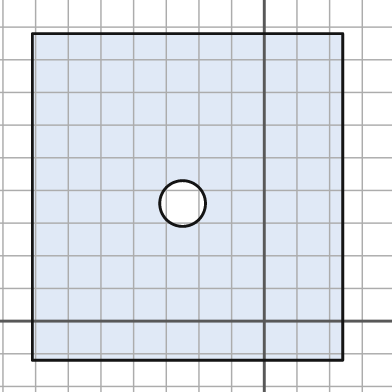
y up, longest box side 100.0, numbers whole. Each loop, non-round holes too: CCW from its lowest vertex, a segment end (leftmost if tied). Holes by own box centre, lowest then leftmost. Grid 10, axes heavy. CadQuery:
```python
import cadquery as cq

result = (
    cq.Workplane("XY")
    .moveTo(-71.0, -12.0)
    .lineTo(24.0, -12.0)
    .lineTo(24.0, 88.0)
    .lineTo(-71.0, 88.0)
    .close()
    .moveTo(-25.0, 36.0)
    .circle(7.0)
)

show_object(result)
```